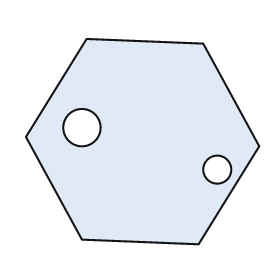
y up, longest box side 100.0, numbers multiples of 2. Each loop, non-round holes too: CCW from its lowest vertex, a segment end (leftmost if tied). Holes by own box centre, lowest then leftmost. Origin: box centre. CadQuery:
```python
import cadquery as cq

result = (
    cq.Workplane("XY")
    .moveTo(24.0, -44.0)
    .lineTo(50.0, -2.0)
    .lineTo(26.0, 42.0)
    .lineTo(-24.0, 44.0)
    .lineTo(-50.0, 2.0)
    .lineTo(-26.0, -42.0)
    .close()
    .moveTo(32.0, -12.0)
    .circle(6.0)
    .moveTo(-26.0, 6.0)
    .circle(8.0)
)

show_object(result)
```